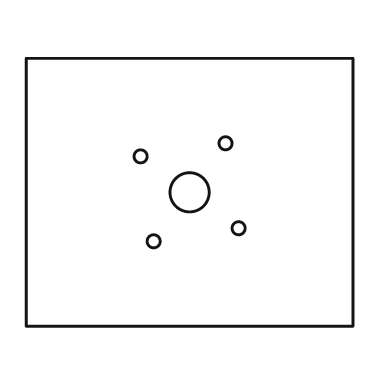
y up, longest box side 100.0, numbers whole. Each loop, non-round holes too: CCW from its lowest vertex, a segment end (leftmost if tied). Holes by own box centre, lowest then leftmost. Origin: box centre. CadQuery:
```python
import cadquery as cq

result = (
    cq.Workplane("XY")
    .moveTo(-50.0, -41.0)
    .lineTo(50.0, -41.0)
    .lineTo(50.0, 41.0)
    .lineTo(-50.0, 41.0)
    .close()
    .moveTo(-11.0, -15.0)
    .circle(2.0)
    .moveTo(15.0, -11.0)
    .circle(2.0)
    .moveTo(0.0, 0.0)
    .circle(6.0)
    .moveTo(-15.0, 11.0)
    .circle(2.0)
    .moveTo(11.0, 15.0)
    .circle(2.0)
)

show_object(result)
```